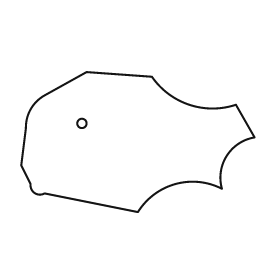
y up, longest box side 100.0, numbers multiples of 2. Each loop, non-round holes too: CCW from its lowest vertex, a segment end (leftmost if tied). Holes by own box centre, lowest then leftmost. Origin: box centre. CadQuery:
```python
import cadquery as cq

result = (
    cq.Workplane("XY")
    .moveTo(0.0, -30.0)
    .threePointArc((16.0, -18.0), (36.0, -20.0))
    .threePointArc((38.0, -6.0), (50.0, 2.0))
    .lineTo(42.0, 16.0)
    .threePointArc((22.0, 16.0), (6.0, 28.0))
    .lineTo(-22.0, 30.0)
    .lineTo(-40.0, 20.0)
    .threePointArc((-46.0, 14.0), (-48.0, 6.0))
    .lineTo(-50.0, -10.0)
    .lineTo(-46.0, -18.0)
    .threePointArc((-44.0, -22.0), (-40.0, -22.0))
    .close()
    .moveTo(-24.0, 8.0)
    .circle(2.0)
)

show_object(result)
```